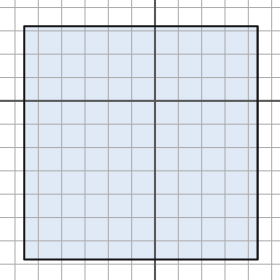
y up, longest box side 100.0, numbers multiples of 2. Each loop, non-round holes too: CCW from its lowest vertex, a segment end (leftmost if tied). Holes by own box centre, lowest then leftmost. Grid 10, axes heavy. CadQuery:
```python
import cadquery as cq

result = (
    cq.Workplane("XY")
    .moveTo(-56.0, -68.0)
    .lineTo(44.0, -68.0)
    .lineTo(44.0, 32.0)
    .lineTo(-56.0, 32.0)
    .close()
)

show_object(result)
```